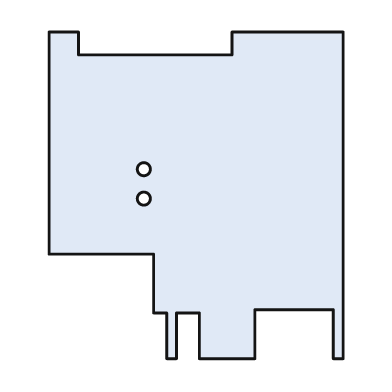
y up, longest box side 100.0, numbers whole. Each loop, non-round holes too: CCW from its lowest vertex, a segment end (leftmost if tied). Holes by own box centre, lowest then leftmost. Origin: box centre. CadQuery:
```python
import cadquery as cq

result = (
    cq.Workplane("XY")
    .moveTo(-9.0, -50.0)
    .lineTo(-6.0, -50.0)
    .lineTo(-6.0, -36.0)
    .lineTo(1.0, -36.0)
    .lineTo(1.0, -50.0)
    .lineTo(18.0, -50.0)
    .lineTo(18.0, -35.0)
    .lineTo(42.0, -35.0)
    .lineTo(42.0, -50.0)
    .lineTo(45.0, -50.0)
    .lineTo(45.0, 50.0)
    .lineTo(11.0, 50.0)
    .lineTo(11.0, 43.0)
    .lineTo(-36.0, 43.0)
    .lineTo(-36.0, 50.0)
    .lineTo(-45.0, 50.0)
    .lineTo(-45.0, -18.0)
    .lineTo(-13.0, -18.0)
    .lineTo(-13.0, -36.0)
    .lineTo(-9.0, -36.0)
    .close()
    .moveTo(-16.0, -1.0)
    .circle(2.0)
    .moveTo(-16.0, 8.0)
    .circle(2.0)
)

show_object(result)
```